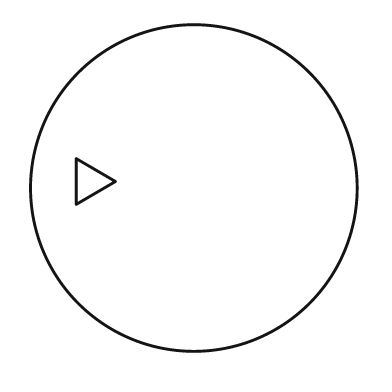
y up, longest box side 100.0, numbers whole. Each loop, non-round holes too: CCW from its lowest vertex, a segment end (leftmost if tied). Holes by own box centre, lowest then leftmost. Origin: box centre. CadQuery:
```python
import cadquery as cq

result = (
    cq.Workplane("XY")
    .moveTo(0.0, 0.0)
    .circle(50.0)
    .moveTo(-36.0, -5.0)
    .lineTo(-24.0, 2.0)
    .lineTo(-36.0, 9.0)
    .close()
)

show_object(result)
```